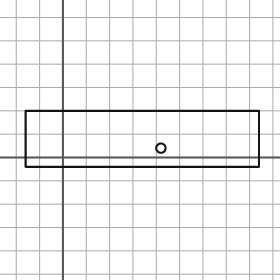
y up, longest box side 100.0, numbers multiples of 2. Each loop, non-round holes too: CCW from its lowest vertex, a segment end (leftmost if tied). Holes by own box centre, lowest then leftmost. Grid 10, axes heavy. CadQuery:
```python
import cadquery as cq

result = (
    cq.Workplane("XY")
    .moveTo(-16.0, -4.0)
    .lineTo(84.0, -4.0)
    .lineTo(84.0, 20.0)
    .lineTo(-16.0, 20.0)
    .close()
    .moveTo(42.0, 4.0)
    .circle(2.0)
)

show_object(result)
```